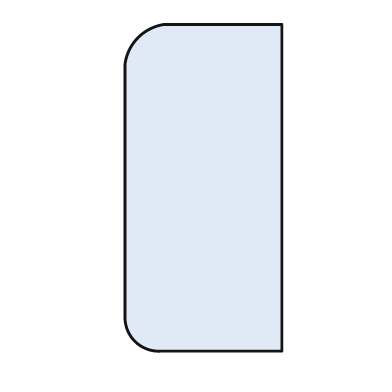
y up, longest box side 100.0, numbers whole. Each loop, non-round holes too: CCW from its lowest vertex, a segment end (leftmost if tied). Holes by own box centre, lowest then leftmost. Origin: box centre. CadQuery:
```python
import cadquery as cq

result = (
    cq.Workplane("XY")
    .moveTo(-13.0, -50.0)
    .lineTo(24.0, -50.0)
    .lineTo(24.0, 50.0)
    .lineTo(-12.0, 50.0)
    .threePointArc((-20.0, 46.0), (-24.0, 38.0))
    .lineTo(-24.0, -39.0)
    .threePointArc((-21.0, -47.0), (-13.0, -50.0))
    .close()
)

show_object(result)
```